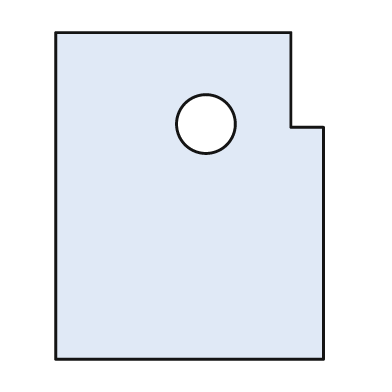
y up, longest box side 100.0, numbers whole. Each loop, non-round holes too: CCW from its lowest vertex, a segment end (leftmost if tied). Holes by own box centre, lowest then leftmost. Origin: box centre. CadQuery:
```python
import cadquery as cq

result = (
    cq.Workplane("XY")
    .moveTo(-41.0, -50.0)
    .lineTo(41.0, -50.0)
    .lineTo(41.0, 21.0)
    .lineTo(31.0, 21.0)
    .lineTo(31.0, 50.0)
    .lineTo(-41.0, 50.0)
    .close()
    .moveTo(5.0, 22.0)
    .circle(9.0)
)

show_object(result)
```